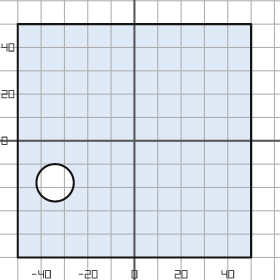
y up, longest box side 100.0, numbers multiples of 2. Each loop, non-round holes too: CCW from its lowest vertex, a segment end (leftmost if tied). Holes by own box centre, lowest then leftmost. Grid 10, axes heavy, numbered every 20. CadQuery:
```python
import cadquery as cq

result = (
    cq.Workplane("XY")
    .moveTo(-50.0, -50.0)
    .lineTo(50.0, -50.0)
    .lineTo(50.0, 50.0)
    .lineTo(-50.0, 50.0)
    .close()
    .moveTo(-34.0, -18.0)
    .circle(8.0)
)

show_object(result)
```